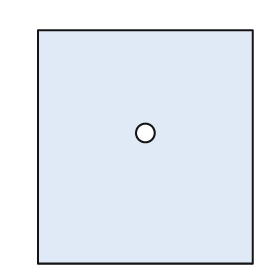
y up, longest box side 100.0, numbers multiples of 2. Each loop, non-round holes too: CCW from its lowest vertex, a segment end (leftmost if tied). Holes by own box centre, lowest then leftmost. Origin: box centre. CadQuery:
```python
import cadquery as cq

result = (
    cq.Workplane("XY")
    .moveTo(-46.0, -50.0)
    .lineTo(46.0, -50.0)
    .lineTo(46.0, 50.0)
    .lineTo(-46.0, 50.0)
    .close()
    .moveTo(0.0, 6.0)
    .circle(4.0)
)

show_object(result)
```